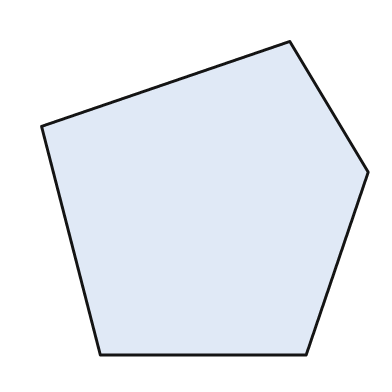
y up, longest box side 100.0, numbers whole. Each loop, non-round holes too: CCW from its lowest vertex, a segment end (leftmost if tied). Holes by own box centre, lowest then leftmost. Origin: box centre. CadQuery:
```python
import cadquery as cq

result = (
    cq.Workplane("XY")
    .moveTo(-32.0, -48.0)
    .lineTo(31.0, -48.0)
    .lineTo(50.0, 8.0)
    .lineTo(26.0, 48.0)
    .lineTo(-50.0, 22.0)
    .close()
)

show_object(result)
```